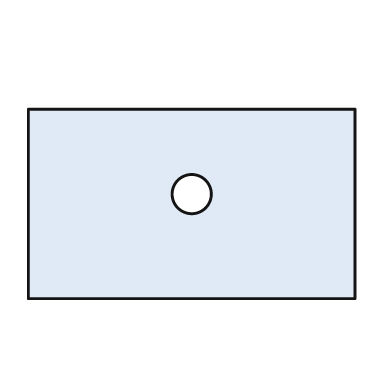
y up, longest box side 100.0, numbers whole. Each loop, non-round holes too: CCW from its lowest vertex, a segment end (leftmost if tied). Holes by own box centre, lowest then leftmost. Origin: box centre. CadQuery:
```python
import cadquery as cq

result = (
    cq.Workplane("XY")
    .moveTo(-50.0, -29.0)
    .lineTo(50.0, -29.0)
    .lineTo(50.0, 29.0)
    .lineTo(-50.0, 29.0)
    .close()
    .moveTo(0.0, 3.0)
    .circle(6.0)
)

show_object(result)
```